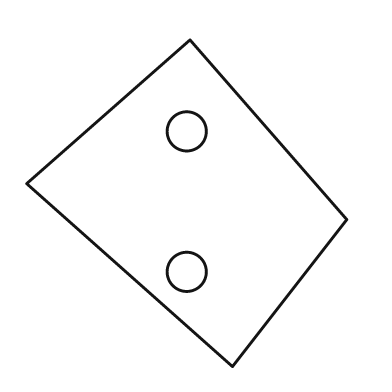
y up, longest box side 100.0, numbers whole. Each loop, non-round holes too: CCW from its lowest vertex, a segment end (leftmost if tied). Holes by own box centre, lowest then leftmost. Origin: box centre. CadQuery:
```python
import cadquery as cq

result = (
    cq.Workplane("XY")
    .moveTo(14.0, -50.0)
    .lineTo(49.0, -5.0)
    .lineTo(1.0, 50.0)
    .lineTo(-49.0, 6.0)
    .close()
    .moveTo(0.0, -21.0)
    .circle(6.0)
    .moveTo(0.0, 22.0)
    .circle(6.0)
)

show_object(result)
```